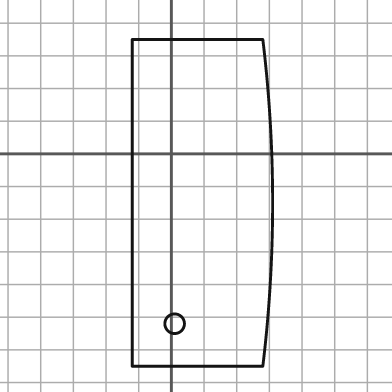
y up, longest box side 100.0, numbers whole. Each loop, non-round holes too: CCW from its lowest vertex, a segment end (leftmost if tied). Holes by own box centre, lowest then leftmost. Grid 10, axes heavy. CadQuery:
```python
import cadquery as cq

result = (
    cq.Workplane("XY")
    .moveTo(-12.0, -65.0)
    .lineTo(28.0, -65.0)
    .threePointArc((31.0, -15.0), (28.0, 35.0))
    .lineTo(-12.0, 35.0)
    .close()
    .moveTo(1.0, -52.0)
    .circle(3.0)
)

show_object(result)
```